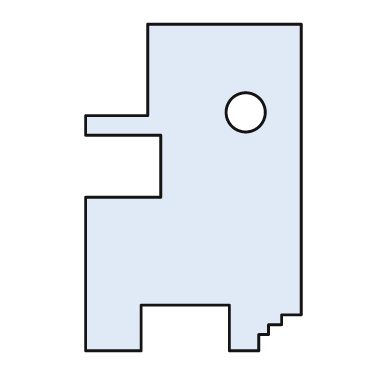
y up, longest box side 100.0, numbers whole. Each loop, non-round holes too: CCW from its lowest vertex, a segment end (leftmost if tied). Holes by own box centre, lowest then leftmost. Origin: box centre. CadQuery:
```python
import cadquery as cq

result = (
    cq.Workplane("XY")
    .moveTo(-33.0, -50.0)
    .lineTo(-16.0, -50.0)
    .lineTo(-16.0, -36.0)
    .lineTo(11.0, -36.0)
    .lineTo(11.0, -50.0)
    .lineTo(20.0, -50.0)
    .lineTo(20.0, -45.0)
    .lineTo(23.0, -45.0)
    .lineTo(23.0, -42.0)
    .lineTo(27.0, -42.0)
    .lineTo(27.0, -39.0)
    .lineTo(33.0, -39.0)
    .lineTo(33.0, 50.0)
    .lineTo(-14.0, 50.0)
    .lineTo(-14.0, 22.0)
    .lineTo(-33.0, 22.0)
    .lineTo(-33.0, 16.0)
    .lineTo(-10.0, 16.0)
    .lineTo(-10.0, -3.0)
    .lineTo(-33.0, -3.0)
    .close()
    .moveTo(16.0, 23.0)
    .circle(6.0)
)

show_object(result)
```